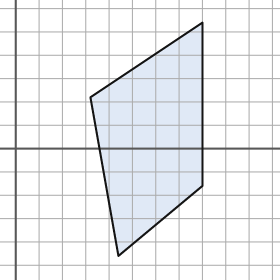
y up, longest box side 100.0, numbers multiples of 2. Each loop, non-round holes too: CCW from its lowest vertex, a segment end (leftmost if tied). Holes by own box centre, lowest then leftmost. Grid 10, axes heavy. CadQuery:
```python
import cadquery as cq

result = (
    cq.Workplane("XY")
    .moveTo(44.0, -46.0)
    .lineTo(80.0, -16.0)
    .lineTo(80.0, 54.0)
    .lineTo(32.0, 22.0)
    .close()
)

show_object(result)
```